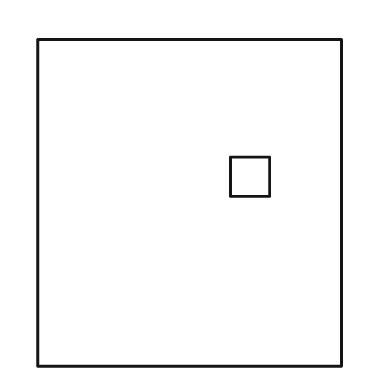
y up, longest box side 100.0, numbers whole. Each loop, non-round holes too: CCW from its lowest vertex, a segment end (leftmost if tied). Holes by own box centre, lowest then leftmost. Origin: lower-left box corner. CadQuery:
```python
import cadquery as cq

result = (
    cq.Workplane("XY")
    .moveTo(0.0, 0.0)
    .lineTo(93.0, 0.0)
    .lineTo(93.0, 100.0)
    .lineTo(0.0, 100.0)
    .close()
    .moveTo(59.0, 52.0)
    .lineTo(71.0, 52.0)
    .lineTo(71.0, 64.0)
    .lineTo(59.0, 64.0)
    .close()
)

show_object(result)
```